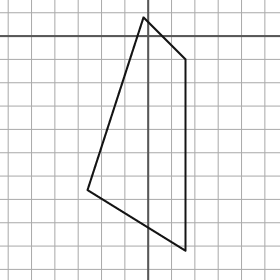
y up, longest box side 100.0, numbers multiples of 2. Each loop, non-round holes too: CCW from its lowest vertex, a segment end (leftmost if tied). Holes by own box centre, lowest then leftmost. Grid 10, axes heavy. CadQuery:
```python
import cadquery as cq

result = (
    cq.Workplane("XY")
    .moveTo(16.0, -92.0)
    .lineTo(16.0, -10.0)
    .lineTo(-2.0, 8.0)
    .lineTo(-26.0, -66.0)
    .close()
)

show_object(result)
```